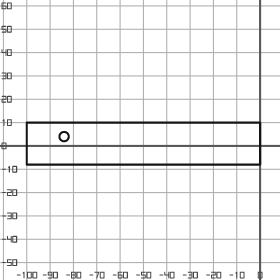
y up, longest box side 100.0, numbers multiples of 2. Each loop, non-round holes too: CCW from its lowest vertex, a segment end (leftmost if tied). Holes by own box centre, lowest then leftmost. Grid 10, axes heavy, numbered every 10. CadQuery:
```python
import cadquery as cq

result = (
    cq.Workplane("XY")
    .moveTo(-100.0, -8.0)
    .lineTo(0.0, -8.0)
    .lineTo(0.0, 10.0)
    .lineTo(-100.0, 10.0)
    .close()
    .moveTo(-84.0, 4.0)
    .circle(2.0)
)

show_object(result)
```